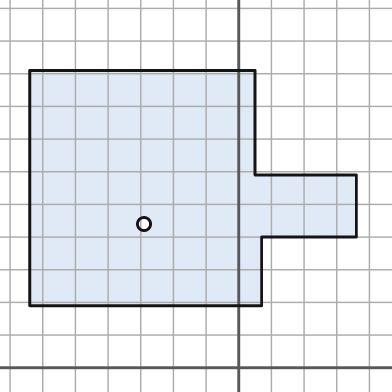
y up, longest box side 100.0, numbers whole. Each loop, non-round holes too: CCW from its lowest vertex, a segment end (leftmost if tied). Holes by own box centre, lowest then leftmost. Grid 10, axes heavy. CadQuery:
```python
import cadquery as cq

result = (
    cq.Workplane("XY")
    .moveTo(-64.0, 19.0)
    .lineTo(7.0, 19.0)
    .lineTo(7.0, 40.0)
    .lineTo(36.0, 40.0)
    .lineTo(36.0, 59.0)
    .lineTo(5.0, 59.0)
    .lineTo(5.0, 91.0)
    .lineTo(-64.0, 91.0)
    .close()
    .moveTo(-29.0, 44.0)
    .circle(2.0)
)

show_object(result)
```